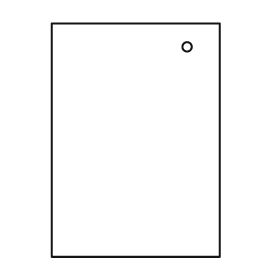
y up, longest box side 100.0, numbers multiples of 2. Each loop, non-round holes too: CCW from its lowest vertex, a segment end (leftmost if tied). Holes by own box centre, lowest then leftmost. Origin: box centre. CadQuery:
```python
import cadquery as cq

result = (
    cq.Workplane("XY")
    .moveTo(-36.0, -50.0)
    .lineTo(36.0, -50.0)
    .lineTo(36.0, 50.0)
    .lineTo(-36.0, 50.0)
    .close()
    .moveTo(22.0, 40.0)
    .circle(2.0)
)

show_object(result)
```